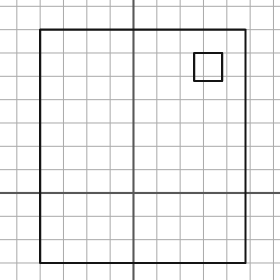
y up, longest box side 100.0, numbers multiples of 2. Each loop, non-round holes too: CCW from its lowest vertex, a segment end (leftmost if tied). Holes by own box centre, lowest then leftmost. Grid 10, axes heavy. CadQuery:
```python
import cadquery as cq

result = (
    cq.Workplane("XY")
    .moveTo(-40.0, -30.0)
    .lineTo(48.0, -30.0)
    .lineTo(48.0, 70.0)
    .lineTo(-40.0, 70.0)
    .close()
    .moveTo(26.0, 48.0)
    .lineTo(38.0, 48.0)
    .lineTo(38.0, 60.0)
    .lineTo(26.0, 60.0)
    .close()
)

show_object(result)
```